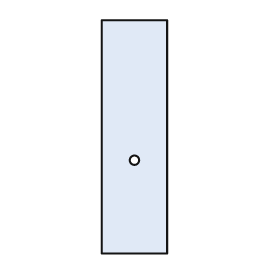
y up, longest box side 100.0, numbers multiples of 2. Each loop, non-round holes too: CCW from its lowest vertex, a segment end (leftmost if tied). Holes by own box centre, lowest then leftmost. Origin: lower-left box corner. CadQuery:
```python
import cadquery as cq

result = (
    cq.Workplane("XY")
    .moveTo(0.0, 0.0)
    .lineTo(28.0, 0.0)
    .lineTo(28.0, 100.0)
    .lineTo(0.0, 100.0)
    .close()
    .moveTo(14.0, 40.0)
    .circle(2.0)
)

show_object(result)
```